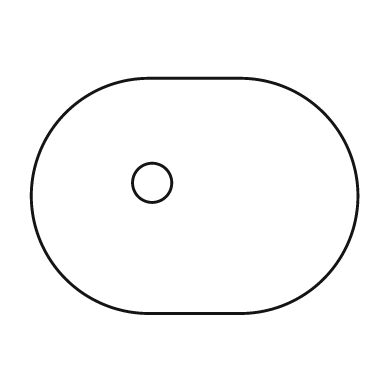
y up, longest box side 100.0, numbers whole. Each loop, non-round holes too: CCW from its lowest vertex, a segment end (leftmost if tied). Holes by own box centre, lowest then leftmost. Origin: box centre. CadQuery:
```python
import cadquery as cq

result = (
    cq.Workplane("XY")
    .moveTo(-14.0, -36.0)
    .lineTo(14.0, -36.0)
    .threePointArc((50.0, 0.0), (14.0, 36.0))
    .lineTo(-14.0, 36.0)
    .threePointArc((-50.0, 0.0), (-14.0, -36.0))
    .close()
    .moveTo(-13.0, 4.0)
    .circle(6.0)
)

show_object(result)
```